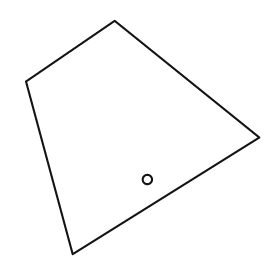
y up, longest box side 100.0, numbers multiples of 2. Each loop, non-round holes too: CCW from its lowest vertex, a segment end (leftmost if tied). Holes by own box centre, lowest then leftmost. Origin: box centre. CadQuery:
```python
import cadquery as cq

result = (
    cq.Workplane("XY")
    .moveTo(-30.0, -50.0)
    .lineTo(50.0, 0.0)
    .lineTo(-12.0, 50.0)
    .lineTo(-50.0, 24.0)
    .close()
    .moveTo(2.0, -18.0)
    .circle(2.0)
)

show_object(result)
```